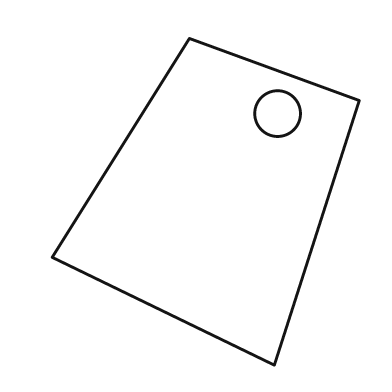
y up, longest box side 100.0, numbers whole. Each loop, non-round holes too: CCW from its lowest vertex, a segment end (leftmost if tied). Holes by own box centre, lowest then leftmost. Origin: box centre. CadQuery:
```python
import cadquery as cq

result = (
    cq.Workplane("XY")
    .moveTo(21.0, -50.0)
    .lineTo(47.0, 31.0)
    .lineTo(-5.0, 50.0)
    .lineTo(-47.0, -17.0)
    .close()
    .moveTo(22.0, 27.0)
    .circle(7.0)
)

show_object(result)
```